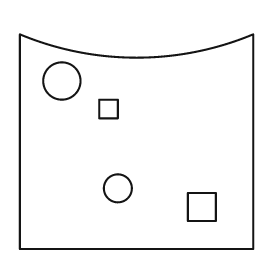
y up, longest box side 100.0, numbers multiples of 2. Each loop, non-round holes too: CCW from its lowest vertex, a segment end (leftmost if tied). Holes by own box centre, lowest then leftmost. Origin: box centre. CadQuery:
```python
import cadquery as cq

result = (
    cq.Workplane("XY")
    .moveTo(-50.0, -46.0)
    .lineTo(50.0, -46.0)
    .lineTo(50.0, 46.0)
    .threePointArc((0.0, 36.0), (-50.0, 46.0))
    .close()
    .moveTo(22.0, -34.0)
    .lineTo(34.0, -34.0)
    .lineTo(34.0, -22.0)
    .lineTo(22.0, -22.0)
    .close()
    .moveTo(-8.0, -20.0)
    .circle(6.0)
    .moveTo(-16.0, 10.0)
    .lineTo(-8.0, 10.0)
    .lineTo(-8.0, 18.0)
    .lineTo(-16.0, 18.0)
    .close()
    .moveTo(-32.0, 26.0)
    .circle(8.0)
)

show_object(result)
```